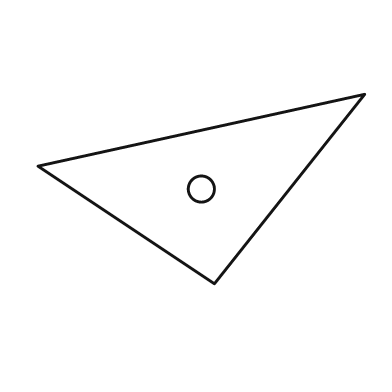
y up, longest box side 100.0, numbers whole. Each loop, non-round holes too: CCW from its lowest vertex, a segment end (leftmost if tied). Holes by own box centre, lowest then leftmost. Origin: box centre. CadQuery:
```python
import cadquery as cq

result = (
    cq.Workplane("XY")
    .moveTo(4.0, -29.0)
    .lineTo(50.0, 29.0)
    .lineTo(-50.0, 7.0)
    .close()
    .moveTo(0.0, 0.0)
    .circle(4.0)
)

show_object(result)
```